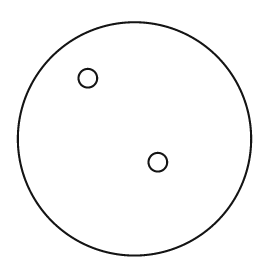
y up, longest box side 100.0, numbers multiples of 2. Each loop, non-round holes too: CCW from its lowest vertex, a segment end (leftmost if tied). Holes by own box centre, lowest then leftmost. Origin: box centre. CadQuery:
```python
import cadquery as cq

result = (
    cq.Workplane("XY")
    .moveTo(0.0, 0.0)
    .circle(50.0)
    .moveTo(10.0, -10.0)
    .circle(4.0)
    .moveTo(-20.0, 26.0)
    .circle(4.0)
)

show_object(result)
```